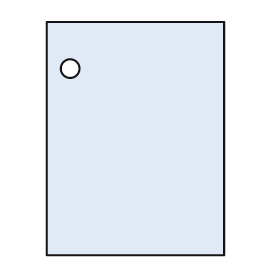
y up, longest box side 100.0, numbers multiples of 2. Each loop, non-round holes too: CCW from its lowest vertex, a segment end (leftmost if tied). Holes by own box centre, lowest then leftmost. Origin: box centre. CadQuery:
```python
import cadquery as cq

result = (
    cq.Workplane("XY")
    .moveTo(-38.0, -50.0)
    .lineTo(38.0, -50.0)
    .lineTo(38.0, 50.0)
    .lineTo(-38.0, 50.0)
    .close()
    .moveTo(-28.0, 30.0)
    .circle(4.0)
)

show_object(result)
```